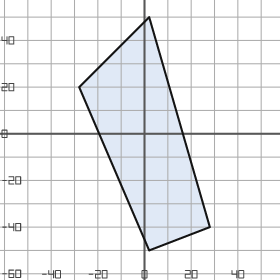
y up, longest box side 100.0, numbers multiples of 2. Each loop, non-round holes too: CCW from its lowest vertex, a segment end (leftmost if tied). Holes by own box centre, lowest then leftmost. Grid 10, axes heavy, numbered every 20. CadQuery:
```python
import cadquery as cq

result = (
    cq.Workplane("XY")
    .moveTo(2.0, -50.0)
    .lineTo(28.0, -40.0)
    .lineTo(2.0, 50.0)
    .lineTo(-28.0, 20.0)
    .close()
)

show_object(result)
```